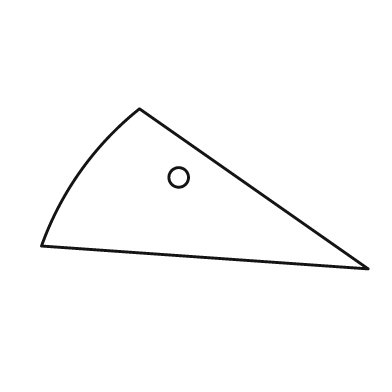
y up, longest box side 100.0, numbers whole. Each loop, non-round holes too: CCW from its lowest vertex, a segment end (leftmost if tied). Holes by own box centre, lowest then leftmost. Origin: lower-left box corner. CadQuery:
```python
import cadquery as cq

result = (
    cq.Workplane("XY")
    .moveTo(100.0, 0.0)
    .lineTo(30.0, 49.0)
    .threePointArc((12.0, 30.0), (0.0, 7.0))
    .close()
    .moveTo(42.0, 28.0)
    .circle(3.0)
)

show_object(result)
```